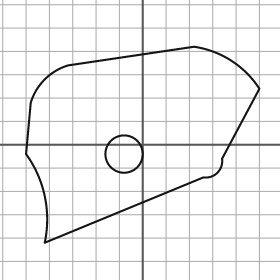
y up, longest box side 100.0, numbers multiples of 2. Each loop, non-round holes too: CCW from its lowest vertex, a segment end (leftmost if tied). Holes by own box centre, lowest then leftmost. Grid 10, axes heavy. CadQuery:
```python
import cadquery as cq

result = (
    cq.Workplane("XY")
    .moveTo(-42.0, -42.0)
    .lineTo(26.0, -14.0)
    .threePointArc((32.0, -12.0), (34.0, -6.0))
    .lineTo(50.0, 24.0)
    .threePointArc((38.0, 36.0), (22.0, 42.0))
    .lineTo(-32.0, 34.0)
    .threePointArc((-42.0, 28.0), (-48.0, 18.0))
    .lineTo(-50.0, -4.0)
    .threePointArc((-42.0, -22.0), (-42.0, -42.0))
    .close()
    .moveTo(-8.0, -4.0)
    .circle(8.0)
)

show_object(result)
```